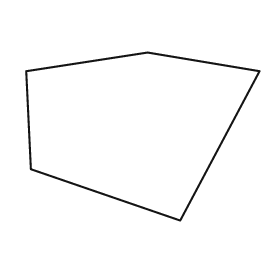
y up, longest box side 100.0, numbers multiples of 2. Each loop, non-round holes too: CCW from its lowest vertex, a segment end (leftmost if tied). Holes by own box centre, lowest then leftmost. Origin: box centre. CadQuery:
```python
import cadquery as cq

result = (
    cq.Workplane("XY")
    .moveTo(16.0, -36.0)
    .lineTo(50.0, 28.0)
    .lineTo(2.0, 36.0)
    .lineTo(-50.0, 28.0)
    .lineTo(-48.0, -14.0)
    .close()
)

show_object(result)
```